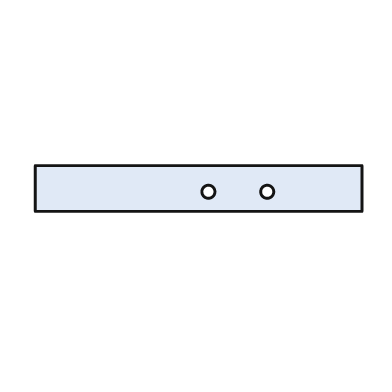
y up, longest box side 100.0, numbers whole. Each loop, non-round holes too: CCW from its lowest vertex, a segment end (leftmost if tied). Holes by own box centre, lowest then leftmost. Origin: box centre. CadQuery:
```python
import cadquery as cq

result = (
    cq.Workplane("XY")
    .moveTo(-50.0, -7.0)
    .lineTo(50.0, -7.0)
    .lineTo(50.0, 7.0)
    .lineTo(-50.0, 7.0)
    .close()
    .moveTo(3.0, -1.0)
    .circle(2.0)
    .moveTo(21.0, -1.0)
    .circle(2.0)
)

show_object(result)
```